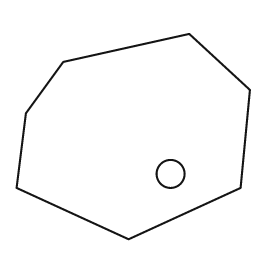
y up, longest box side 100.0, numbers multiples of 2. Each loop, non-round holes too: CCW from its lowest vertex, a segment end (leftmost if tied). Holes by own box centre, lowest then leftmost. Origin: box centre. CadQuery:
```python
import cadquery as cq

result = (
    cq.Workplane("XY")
    .moveTo(-2.0, -44.0)
    .lineTo(46.0, -22.0)
    .lineTo(50.0, 20.0)
    .lineTo(24.0, 44.0)
    .lineTo(-30.0, 32.0)
    .lineTo(-46.0, 10.0)
    .lineTo(-50.0, -22.0)
    .close()
    .moveTo(16.0, -16.0)
    .circle(6.0)
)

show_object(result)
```